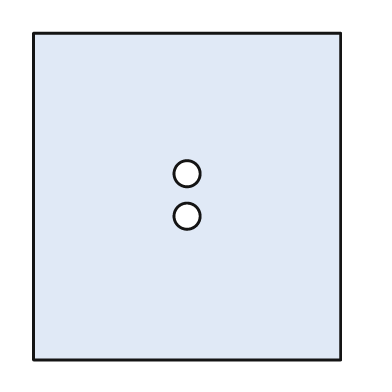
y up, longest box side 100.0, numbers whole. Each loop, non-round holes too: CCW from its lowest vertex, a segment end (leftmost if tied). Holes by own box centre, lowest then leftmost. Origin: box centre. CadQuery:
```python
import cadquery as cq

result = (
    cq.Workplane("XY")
    .moveTo(-47.0, -50.0)
    .lineTo(47.0, -50.0)
    .lineTo(47.0, 50.0)
    .lineTo(-47.0, 50.0)
    .close()
    .moveTo(0.0, -6.0)
    .circle(4.0)
    .moveTo(0.0, 7.0)
    .circle(4.0)
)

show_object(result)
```